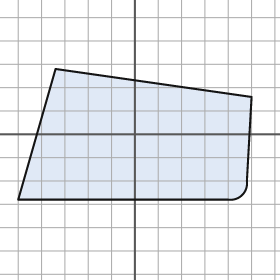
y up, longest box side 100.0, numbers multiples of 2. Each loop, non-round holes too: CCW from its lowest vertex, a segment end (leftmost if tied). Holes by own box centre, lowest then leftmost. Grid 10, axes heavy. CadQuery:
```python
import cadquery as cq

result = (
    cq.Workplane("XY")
    .moveTo(-50.0, -28.0)
    .lineTo(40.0, -28.0)
    .threePointArc((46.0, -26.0), (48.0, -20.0))
    .lineTo(50.0, 16.0)
    .lineTo(-34.0, 28.0)
    .close()
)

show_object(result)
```